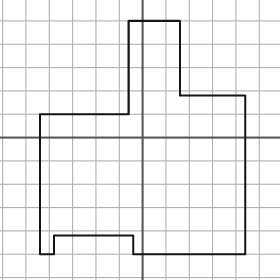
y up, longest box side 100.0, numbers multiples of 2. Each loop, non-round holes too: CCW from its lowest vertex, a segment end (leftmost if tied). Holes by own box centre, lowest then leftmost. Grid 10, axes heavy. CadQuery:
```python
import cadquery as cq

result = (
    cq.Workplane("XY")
    .moveTo(-44.0, -50.0)
    .lineTo(-38.0, -50.0)
    .lineTo(-38.0, -42.0)
    .lineTo(-4.0, -42.0)
    .lineTo(-4.0, -50.0)
    .lineTo(44.0, -50.0)
    .lineTo(44.0, 18.0)
    .lineTo(16.0, 18.0)
    .lineTo(16.0, 50.0)
    .lineTo(-6.0, 50.0)
    .lineTo(-6.0, 10.0)
    .lineTo(-44.0, 10.0)
    .close()
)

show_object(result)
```